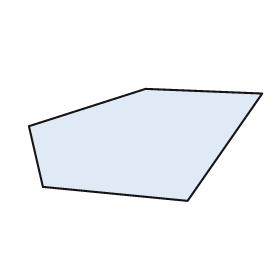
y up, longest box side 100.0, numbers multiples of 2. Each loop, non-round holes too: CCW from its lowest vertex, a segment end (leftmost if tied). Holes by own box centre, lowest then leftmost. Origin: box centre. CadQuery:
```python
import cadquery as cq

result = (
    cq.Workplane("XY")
    .moveTo(18.0, -24.0)
    .lineTo(50.0, 22.0)
    .lineTo(0.0, 24.0)
    .lineTo(-50.0, 8.0)
    .lineTo(-44.0, -18.0)
    .close()
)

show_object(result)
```